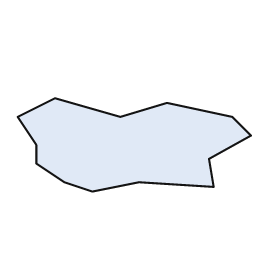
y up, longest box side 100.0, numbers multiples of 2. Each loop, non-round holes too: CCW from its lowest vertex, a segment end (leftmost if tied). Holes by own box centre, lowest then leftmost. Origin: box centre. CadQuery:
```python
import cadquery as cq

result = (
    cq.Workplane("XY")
    .moveTo(-18.0, -20.0)
    .lineTo(2.0, -16.0)
    .lineTo(34.0, -18.0)
    .lineTo(32.0, -6.0)
    .lineTo(50.0, 4.0)
    .lineTo(42.0, 12.0)
    .lineTo(14.0, 18.0)
    .lineTo(-6.0, 12.0)
    .lineTo(-34.0, 20.0)
    .lineTo(-50.0, 12.0)
    .lineTo(-42.0, 0.0)
    .lineTo(-42.0, -8.0)
    .lineTo(-30.0, -16.0)
    .close()
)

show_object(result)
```